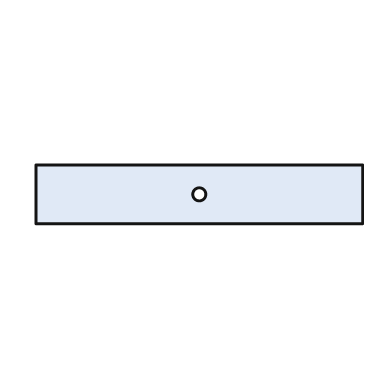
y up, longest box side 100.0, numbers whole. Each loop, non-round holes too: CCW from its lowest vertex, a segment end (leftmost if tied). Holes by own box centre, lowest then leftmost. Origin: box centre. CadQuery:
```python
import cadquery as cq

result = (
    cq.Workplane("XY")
    .moveTo(-50.0, -9.0)
    .lineTo(50.0, -9.0)
    .lineTo(50.0, 9.0)
    .lineTo(-50.0, 9.0)
    .close()
    .moveTo(0.0, 0.0)
    .circle(2.0)
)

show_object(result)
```